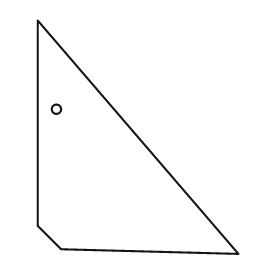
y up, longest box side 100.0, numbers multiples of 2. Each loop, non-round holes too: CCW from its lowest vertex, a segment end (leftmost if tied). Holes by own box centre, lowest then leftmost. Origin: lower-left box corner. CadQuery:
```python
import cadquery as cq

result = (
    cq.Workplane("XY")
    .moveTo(86.0, 0.0)
    .lineTo(0.0, 100.0)
    .lineTo(0.0, 12.0)
    .lineTo(10.0, 2.0)
    .close()
    .moveTo(8.0, 62.0)
    .circle(2.0)
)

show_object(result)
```